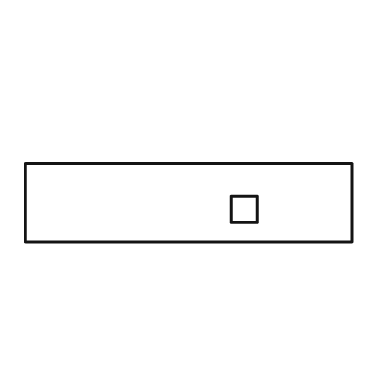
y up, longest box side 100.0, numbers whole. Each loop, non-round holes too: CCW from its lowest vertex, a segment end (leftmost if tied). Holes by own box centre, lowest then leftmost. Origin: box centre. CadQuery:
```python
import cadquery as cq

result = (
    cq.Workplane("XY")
    .moveTo(-50.0, -12.0)
    .lineTo(50.0, -12.0)
    .lineTo(50.0, 12.0)
    .lineTo(-50.0, 12.0)
    .close()
    .moveTo(13.0, -6.0)
    .lineTo(21.0, -6.0)
    .lineTo(21.0, 2.0)
    .lineTo(13.0, 2.0)
    .close()
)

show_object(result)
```